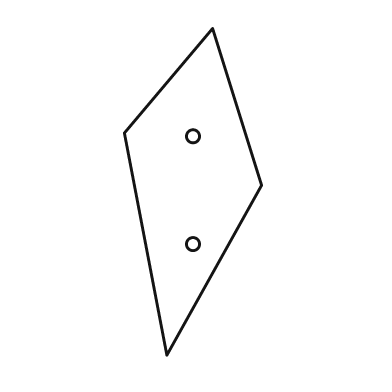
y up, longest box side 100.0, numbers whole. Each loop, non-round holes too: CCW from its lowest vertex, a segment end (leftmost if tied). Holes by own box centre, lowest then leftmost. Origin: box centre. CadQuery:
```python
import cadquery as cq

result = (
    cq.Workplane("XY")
    .moveTo(-8.0, -50.0)
    .lineTo(21.0, 2.0)
    .lineTo(6.0, 50.0)
    .lineTo(-21.0, 18.0)
    .close()
    .moveTo(0.0, -16.0)
    .circle(2.0)
    .moveTo(0.0, 17.0)
    .circle(2.0)
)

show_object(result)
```